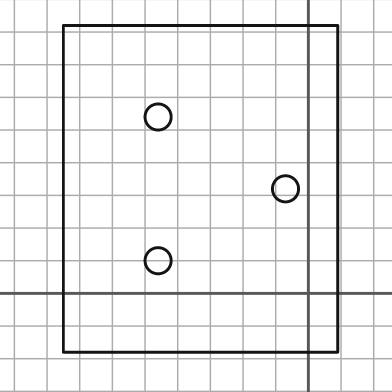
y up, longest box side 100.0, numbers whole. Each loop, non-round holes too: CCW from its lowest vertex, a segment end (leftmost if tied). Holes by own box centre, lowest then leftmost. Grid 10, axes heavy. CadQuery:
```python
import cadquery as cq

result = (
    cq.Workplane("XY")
    .moveTo(-75.0, -18.0)
    .lineTo(9.0, -18.0)
    .lineTo(9.0, 82.0)
    .lineTo(-75.0, 82.0)
    .close()
    .moveTo(-46.0, 10.0)
    .circle(4.0)
    .moveTo(-7.0, 32.0)
    .circle(4.0)
    .moveTo(-46.0, 54.0)
    .circle(4.0)
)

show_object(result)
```